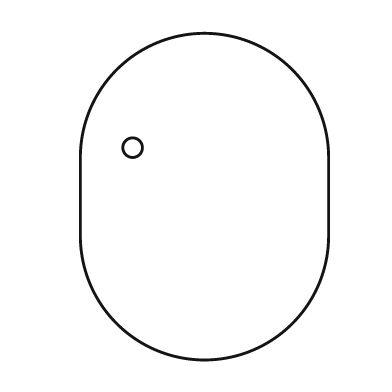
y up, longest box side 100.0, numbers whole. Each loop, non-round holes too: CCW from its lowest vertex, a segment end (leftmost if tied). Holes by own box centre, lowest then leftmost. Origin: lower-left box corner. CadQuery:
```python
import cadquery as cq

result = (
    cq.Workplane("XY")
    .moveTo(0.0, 38.0)
    .threePointArc((38.0, 0.0), (76.0, 38.0))
    .lineTo(76.0, 62.0)
    .threePointArc((38.0, 100.0), (0.0, 62.0))
    .close()
    .moveTo(16.0, 65.0)
    .circle(3.0)
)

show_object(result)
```